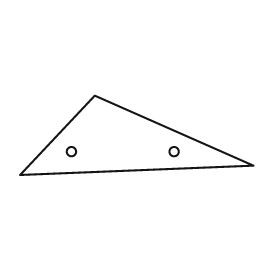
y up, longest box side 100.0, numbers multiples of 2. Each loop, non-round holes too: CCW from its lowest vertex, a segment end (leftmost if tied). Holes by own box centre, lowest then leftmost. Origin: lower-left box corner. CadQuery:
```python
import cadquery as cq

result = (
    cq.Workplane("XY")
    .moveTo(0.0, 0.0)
    .lineTo(100.0, 4.0)
    .lineTo(32.0, 34.0)
    .close()
    .moveTo(22.0, 10.0)
    .circle(2.0)
    .moveTo(66.0, 10.0)
    .circle(2.0)
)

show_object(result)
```